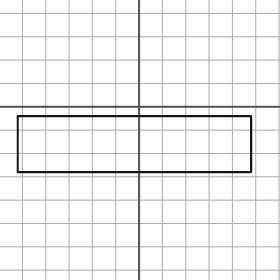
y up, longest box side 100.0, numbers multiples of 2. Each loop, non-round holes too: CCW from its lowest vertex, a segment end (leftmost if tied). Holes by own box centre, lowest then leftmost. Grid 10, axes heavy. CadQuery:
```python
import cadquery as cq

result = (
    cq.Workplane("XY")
    .moveTo(-52.0, -28.0)
    .lineTo(48.0, -28.0)
    .lineTo(48.0, -4.0)
    .lineTo(-52.0, -4.0)
    .close()
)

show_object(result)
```